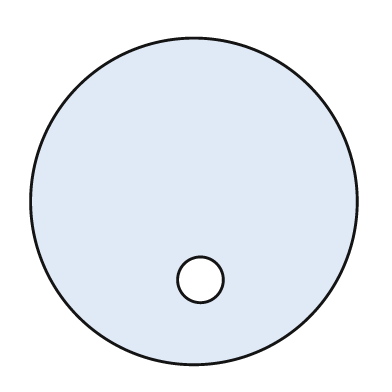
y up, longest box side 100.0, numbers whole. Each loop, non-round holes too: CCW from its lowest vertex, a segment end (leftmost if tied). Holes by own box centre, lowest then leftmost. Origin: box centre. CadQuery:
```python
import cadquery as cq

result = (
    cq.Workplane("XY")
    .moveTo(0.0, 0.0)
    .circle(50.0)
    .moveTo(2.0, -24.0)
    .circle(7.0)
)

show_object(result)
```